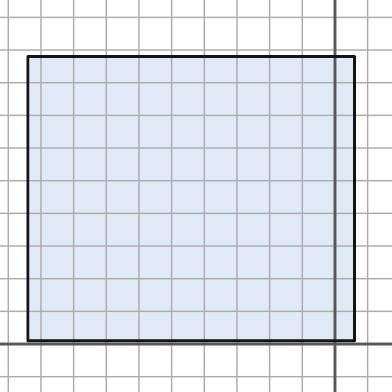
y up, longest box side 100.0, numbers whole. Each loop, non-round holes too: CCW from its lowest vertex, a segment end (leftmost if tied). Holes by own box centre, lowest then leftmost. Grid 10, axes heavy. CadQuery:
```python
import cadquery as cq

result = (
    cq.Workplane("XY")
    .moveTo(-94.0, 1.0)
    .lineTo(6.0, 1.0)
    .lineTo(6.0, 88.0)
    .lineTo(-94.0, 88.0)
    .close()
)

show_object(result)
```